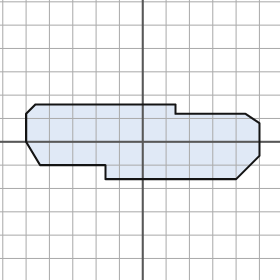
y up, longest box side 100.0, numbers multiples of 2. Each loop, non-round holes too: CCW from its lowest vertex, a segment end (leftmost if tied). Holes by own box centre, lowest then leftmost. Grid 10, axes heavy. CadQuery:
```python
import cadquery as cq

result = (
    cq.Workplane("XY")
    .moveTo(-16.0, -16.0)
    .lineTo(40.0, -16.0)
    .lineTo(50.0, -6.0)
    .lineTo(50.0, 8.0)
    .lineTo(44.0, 12.0)
    .lineTo(14.0, 12.0)
    .lineTo(14.0, 16.0)
    .lineTo(-46.0, 16.0)
    .lineTo(-50.0, 12.0)
    .lineTo(-50.0, 0.0)
    .lineTo(-44.0, -10.0)
    .lineTo(-16.0, -10.0)
    .close()
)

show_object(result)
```